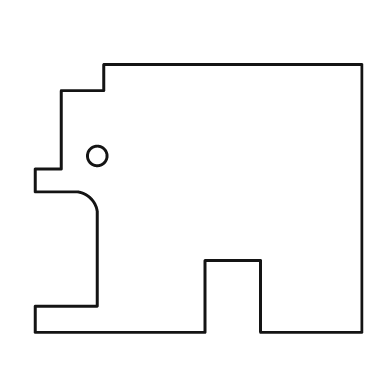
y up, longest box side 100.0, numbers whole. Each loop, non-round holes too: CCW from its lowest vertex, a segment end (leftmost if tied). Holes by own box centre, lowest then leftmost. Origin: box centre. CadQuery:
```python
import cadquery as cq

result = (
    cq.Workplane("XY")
    .moveTo(-50.0, -41.0)
    .lineTo(2.0, -41.0)
    .lineTo(2.0, -19.0)
    .lineTo(19.0, -19.0)
    .lineTo(19.0, -41.0)
    .lineTo(50.0, -41.0)
    .lineTo(50.0, 41.0)
    .lineTo(-29.0, 41.0)
    .lineTo(-29.0, 33.0)
    .lineTo(-42.0, 33.0)
    .lineTo(-42.0, 9.0)
    .lineTo(-50.0, 9.0)
    .lineTo(-50.0, 2.0)
    .lineTo(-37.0, 2.0)
    .threePointArc((-33.0, 0.0), (-31.0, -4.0))
    .lineTo(-31.0, -33.0)
    .lineTo(-50.0, -33.0)
    .close()
    .moveTo(-31.0, 13.0)
    .circle(3.0)
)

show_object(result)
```